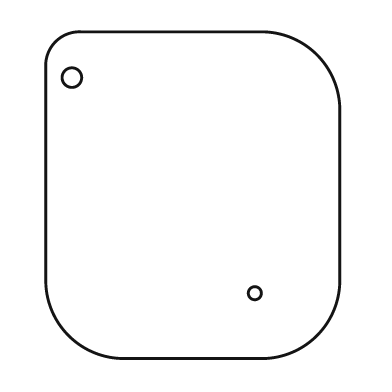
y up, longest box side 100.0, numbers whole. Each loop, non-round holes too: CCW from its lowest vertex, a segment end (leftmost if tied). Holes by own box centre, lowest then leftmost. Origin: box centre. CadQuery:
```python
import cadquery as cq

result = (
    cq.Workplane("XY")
    .moveTo(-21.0, -50.0)
    .lineTo(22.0, -50.0)
    .threePointArc((38.0, -43.0), (45.0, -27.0))
    .lineTo(45.0, 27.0)
    .threePointArc((38.0, 43.0), (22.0, 50.0))
    .lineTo(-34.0, 50.0)
    .threePointArc((-42.0, 47.0), (-45.0, 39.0))
    .lineTo(-45.0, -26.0)
    .threePointArc((-38.0, -43.0), (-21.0, -50.0))
    .close()
    .moveTo(19.0, -30.0)
    .circle(2.0)
    .moveTo(-37.0, 36.0)
    .circle(3.0)
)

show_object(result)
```